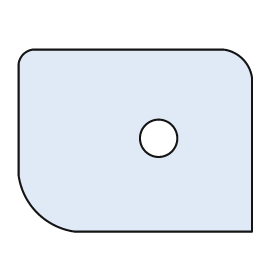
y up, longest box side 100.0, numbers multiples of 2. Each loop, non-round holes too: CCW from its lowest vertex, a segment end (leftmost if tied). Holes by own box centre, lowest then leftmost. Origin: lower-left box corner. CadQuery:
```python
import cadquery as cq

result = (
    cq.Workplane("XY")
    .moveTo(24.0, 0.0)
    .lineTo(100.0, 0.0)
    .lineTo(100.0, 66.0)
    .threePointArc((96.0, 74.0), (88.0, 78.0))
    .lineTo(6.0, 78.0)
    .threePointArc((2.0, 76.0), (0.0, 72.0))
    .lineTo(0.0, 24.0)
    .threePointArc((8.0, 8.0), (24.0, 0.0))
    .close()
    .moveTo(60.0, 40.0)
    .circle(8.0)
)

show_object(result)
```